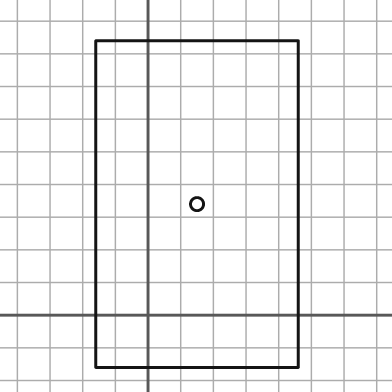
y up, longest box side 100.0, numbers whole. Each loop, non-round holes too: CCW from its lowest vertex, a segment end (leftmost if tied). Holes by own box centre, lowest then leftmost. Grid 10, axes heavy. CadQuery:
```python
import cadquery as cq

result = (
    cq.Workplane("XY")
    .moveTo(-16.0, -16.0)
    .lineTo(46.0, -16.0)
    .lineTo(46.0, 84.0)
    .lineTo(-16.0, 84.0)
    .close()
    .moveTo(15.0, 34.0)
    .circle(2.0)
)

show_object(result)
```